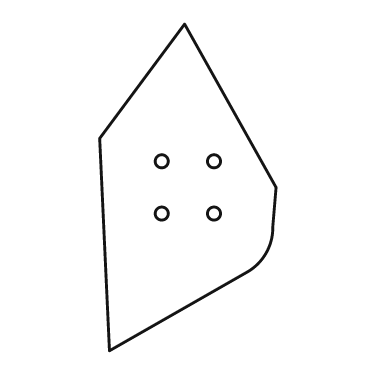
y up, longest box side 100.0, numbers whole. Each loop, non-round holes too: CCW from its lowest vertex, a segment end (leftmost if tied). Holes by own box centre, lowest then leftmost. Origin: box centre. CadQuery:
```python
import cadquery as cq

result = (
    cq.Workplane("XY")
    .moveTo(-24.0, -50.0)
    .lineTo(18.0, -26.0)
    .threePointArc((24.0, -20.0), (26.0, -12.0))
    .lineTo(27.0, 0.0)
    .lineTo(-1.0, 50.0)
    .lineTo(-27.0, 15.0)
    .close()
    .moveTo(-8.0, -8.0)
    .circle(2.0)
    .moveTo(8.0, -8.0)
    .circle(2.0)
    .moveTo(-8.0, 8.0)
    .circle(2.0)
    .moveTo(8.0, 8.0)
    .circle(2.0)
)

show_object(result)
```